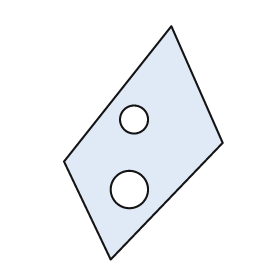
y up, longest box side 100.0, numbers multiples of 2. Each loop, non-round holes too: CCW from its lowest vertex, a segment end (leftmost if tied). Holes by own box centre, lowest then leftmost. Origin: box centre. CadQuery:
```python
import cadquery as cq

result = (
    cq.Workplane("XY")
    .moveTo(-14.0, -50.0)
    .lineTo(34.0, 0.0)
    .lineTo(12.0, 50.0)
    .lineTo(-34.0, -8.0)
    .close()
    .moveTo(-6.0, -20.0)
    .circle(8.0)
    .moveTo(-4.0, 10.0)
    .circle(6.0)
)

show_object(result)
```